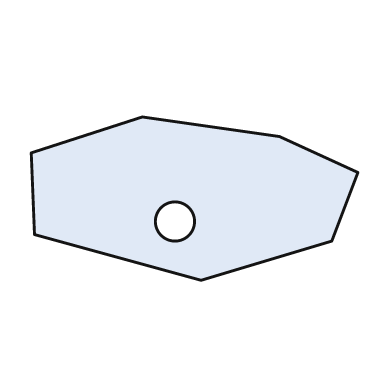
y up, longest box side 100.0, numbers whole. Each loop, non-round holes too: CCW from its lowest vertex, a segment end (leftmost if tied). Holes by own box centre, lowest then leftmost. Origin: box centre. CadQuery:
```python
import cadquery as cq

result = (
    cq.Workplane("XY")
    .moveTo(2.0, -25.0)
    .lineTo(42.0, -13.0)
    .lineTo(50.0, 8.0)
    .lineTo(26.0, 19.0)
    .lineTo(-16.0, 25.0)
    .lineTo(-50.0, 14.0)
    .lineTo(-49.0, -11.0)
    .close()
    .moveTo(-6.0, -7.0)
    .circle(6.0)
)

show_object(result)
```